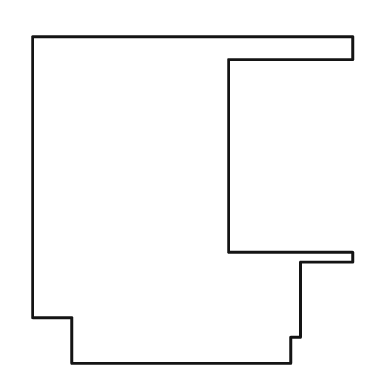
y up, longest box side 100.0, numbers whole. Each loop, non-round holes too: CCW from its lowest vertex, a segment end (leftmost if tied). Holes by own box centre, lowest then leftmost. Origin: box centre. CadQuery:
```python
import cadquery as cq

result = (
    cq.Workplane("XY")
    .moveTo(-37.0, -50.0)
    .lineTo(30.0, -50.0)
    .lineTo(30.0, -42.0)
    .lineTo(33.0, -42.0)
    .lineTo(33.0, -19.0)
    .lineTo(49.0, -19.0)
    .lineTo(49.0, -16.0)
    .lineTo(11.0, -16.0)
    .lineTo(11.0, 43.0)
    .lineTo(49.0, 43.0)
    .lineTo(49.0, 50.0)
    .lineTo(-49.0, 50.0)
    .lineTo(-49.0, -36.0)
    .lineTo(-37.0, -36.0)
    .close()
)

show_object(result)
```